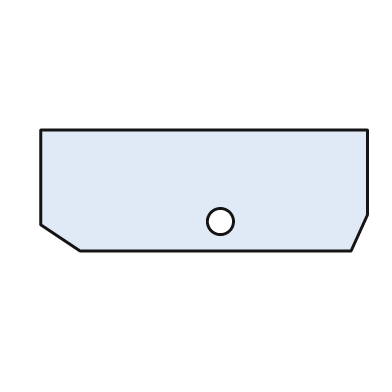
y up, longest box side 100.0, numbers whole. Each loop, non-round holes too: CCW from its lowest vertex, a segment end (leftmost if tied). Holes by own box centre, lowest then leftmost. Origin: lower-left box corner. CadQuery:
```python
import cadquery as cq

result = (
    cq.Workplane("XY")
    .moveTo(12.0, 0.0)
    .lineTo(95.0, 0.0)
    .lineTo(100.0, 11.0)
    .lineTo(100.0, 37.0)
    .lineTo(0.0, 37.0)
    .lineTo(0.0, 8.0)
    .close()
    .moveTo(55.0, 9.0)
    .circle(4.0)
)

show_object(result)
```